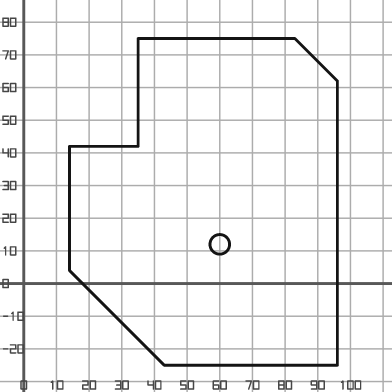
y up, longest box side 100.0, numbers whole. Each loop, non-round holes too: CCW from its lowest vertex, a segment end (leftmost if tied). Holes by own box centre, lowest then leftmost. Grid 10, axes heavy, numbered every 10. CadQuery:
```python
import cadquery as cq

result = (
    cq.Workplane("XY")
    .moveTo(43.0, -25.0)
    .lineTo(96.0, -25.0)
    .lineTo(96.0, 62.0)
    .lineTo(83.0, 75.0)
    .lineTo(35.0, 75.0)
    .lineTo(35.0, 42.0)
    .lineTo(14.0, 42.0)
    .lineTo(14.0, 4.0)
    .close()
    .moveTo(60.0, 12.0)
    .circle(3.0)
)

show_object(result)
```